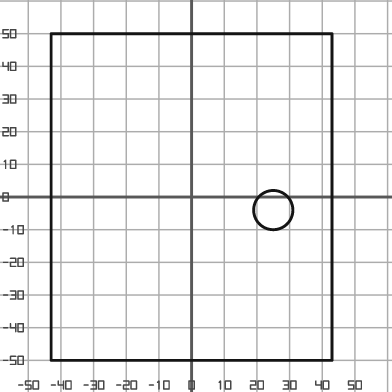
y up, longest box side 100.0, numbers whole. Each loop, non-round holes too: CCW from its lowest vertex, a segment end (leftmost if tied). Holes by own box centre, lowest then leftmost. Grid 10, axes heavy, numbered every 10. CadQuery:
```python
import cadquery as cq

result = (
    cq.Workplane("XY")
    .moveTo(-43.0, -50.0)
    .lineTo(43.0, -50.0)
    .lineTo(43.0, 50.0)
    .lineTo(-43.0, 50.0)
    .close()
    .moveTo(25.0, -4.0)
    .circle(6.0)
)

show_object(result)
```